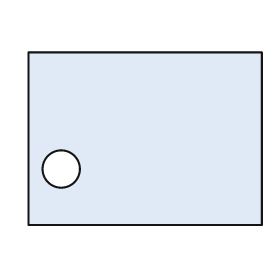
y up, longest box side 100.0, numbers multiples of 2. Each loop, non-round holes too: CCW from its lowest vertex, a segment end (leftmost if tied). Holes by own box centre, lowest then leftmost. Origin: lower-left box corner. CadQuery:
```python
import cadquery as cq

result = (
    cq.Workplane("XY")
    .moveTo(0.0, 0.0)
    .lineTo(100.0, 0.0)
    .lineTo(100.0, 74.0)
    .lineTo(0.0, 74.0)
    .close()
    .moveTo(14.0, 24.0)
    .circle(8.0)
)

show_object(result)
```